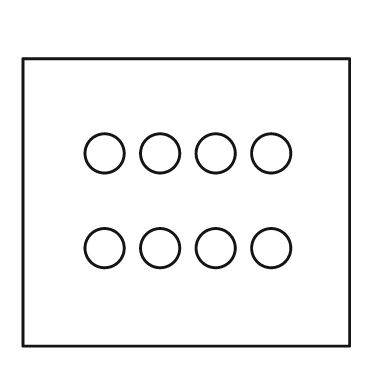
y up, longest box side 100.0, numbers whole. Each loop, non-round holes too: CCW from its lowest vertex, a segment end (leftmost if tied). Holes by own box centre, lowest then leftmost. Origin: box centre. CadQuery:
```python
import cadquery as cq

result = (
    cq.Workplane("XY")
    .moveTo(-50.0, -44.0)
    .lineTo(50.0, -44.0)
    .lineTo(50.0, 44.0)
    .lineTo(-50.0, 44.0)
    .close()
    .moveTo(-25.0, -14.0)
    .circle(6.0)
    .moveTo(-8.0, -14.0)
    .circle(6.0)
    .moveTo(9.0, -14.0)
    .circle(6.0)
    .moveTo(26.0, -14.0)
    .circle(6.0)
    .moveTo(-25.0, 15.0)
    .circle(6.0)
    .moveTo(-8.0, 15.0)
    .circle(6.0)
    .moveTo(9.0, 15.0)
    .circle(6.0)
    .moveTo(26.0, 15.0)
    .circle(6.0)
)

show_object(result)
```